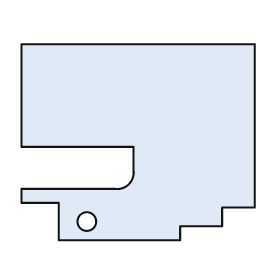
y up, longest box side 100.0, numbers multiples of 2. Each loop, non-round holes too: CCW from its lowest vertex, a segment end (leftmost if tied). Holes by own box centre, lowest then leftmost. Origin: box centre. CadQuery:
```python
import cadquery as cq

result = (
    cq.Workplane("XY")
    .moveTo(-34.0, -42.0)
    .lineTo(18.0, -42.0)
    .lineTo(18.0, -36.0)
    .lineTo(36.0, -36.0)
    .lineTo(36.0, -28.0)
    .lineTo(50.0, -28.0)
    .lineTo(50.0, 42.0)
    .lineTo(-50.0, 42.0)
    .lineTo(-50.0, -2.0)
    .lineTo(-2.0, -2.0)
    .lineTo(-2.0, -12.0)
    .threePointArc((-4.0, -18.0), (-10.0, -20.0))
    .lineTo(-50.0, -20.0)
    .lineTo(-50.0, -26.0)
    .lineTo(-34.0, -26.0)
    .close()
    .moveTo(-22.0, -34.0)
    .circle(4.0)
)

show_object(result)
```